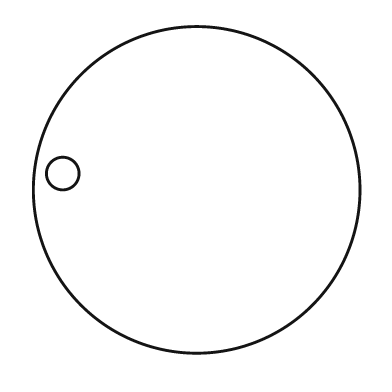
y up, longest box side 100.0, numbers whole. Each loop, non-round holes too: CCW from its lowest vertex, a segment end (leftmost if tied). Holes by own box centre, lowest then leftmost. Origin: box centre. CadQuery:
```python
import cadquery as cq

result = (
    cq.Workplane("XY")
    .moveTo(0.0, 0.0)
    .circle(50.0)
    .moveTo(-41.0, 5.0)
    .circle(5.0)
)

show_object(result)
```